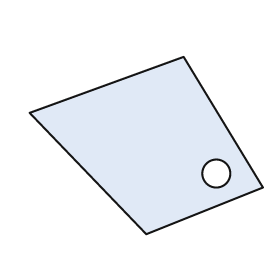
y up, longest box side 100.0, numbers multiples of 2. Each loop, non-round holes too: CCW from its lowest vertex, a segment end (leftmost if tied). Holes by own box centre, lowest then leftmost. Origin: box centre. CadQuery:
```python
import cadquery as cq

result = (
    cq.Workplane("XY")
    .moveTo(0.0, -38.0)
    .lineTo(50.0, -18.0)
    .lineTo(16.0, 38.0)
    .lineTo(-50.0, 14.0)
    .close()
    .moveTo(30.0, -12.0)
    .circle(6.0)
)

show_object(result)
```